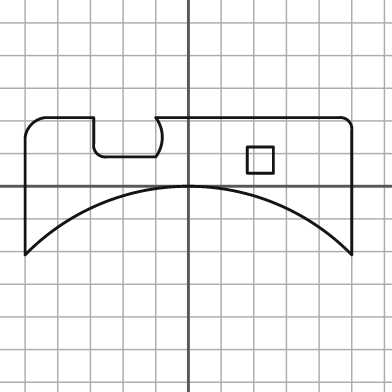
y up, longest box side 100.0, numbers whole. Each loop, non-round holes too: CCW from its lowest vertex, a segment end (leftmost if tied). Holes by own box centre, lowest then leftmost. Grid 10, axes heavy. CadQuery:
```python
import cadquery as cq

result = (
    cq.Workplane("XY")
    .moveTo(-50.0, -21.0)
    .threePointArc((0.0, 0.0), (50.0, -21.0))
    .lineTo(50.0, 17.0)
    .threePointArc((49.0, 20.0), (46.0, 21.0))
    .lineTo(-10.0, 21.0)
    .threePointArc((-8.0, 15.0), (-10.0, 9.0))
    .lineTo(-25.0, 9.0)
    .threePointArc((-28.0, 10.0), (-29.0, 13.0))
    .lineTo(-29.0, 21.0)
    .lineTo(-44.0, 21.0)
    .threePointArc((-48.0, 19.0), (-50.0, 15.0))
    .close()
    .moveTo(18.0, 4.0)
    .lineTo(26.0, 4.0)
    .lineTo(26.0, 12.0)
    .lineTo(18.0, 12.0)
    .close()
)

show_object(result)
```